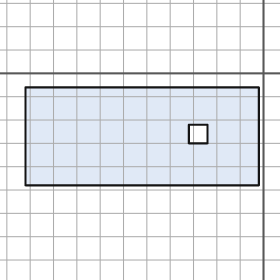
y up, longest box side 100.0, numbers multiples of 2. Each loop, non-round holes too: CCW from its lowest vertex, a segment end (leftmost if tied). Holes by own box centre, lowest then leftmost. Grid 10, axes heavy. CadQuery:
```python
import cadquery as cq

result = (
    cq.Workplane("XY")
    .moveTo(-102.0, -48.0)
    .lineTo(-2.0, -48.0)
    .lineTo(-2.0, -6.0)
    .lineTo(-102.0, -6.0)
    .close()
    .moveTo(-32.0, -30.0)
    .lineTo(-24.0, -30.0)
    .lineTo(-24.0, -22.0)
    .lineTo(-32.0, -22.0)
    .close()
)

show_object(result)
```